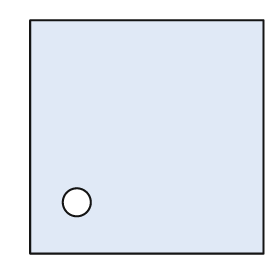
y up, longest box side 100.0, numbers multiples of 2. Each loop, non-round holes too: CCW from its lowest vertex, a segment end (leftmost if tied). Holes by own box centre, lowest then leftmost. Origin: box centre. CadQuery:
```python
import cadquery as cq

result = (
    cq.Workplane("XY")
    .moveTo(-50.0, -50.0)
    .lineTo(50.0, -50.0)
    .lineTo(50.0, 50.0)
    .lineTo(-50.0, 50.0)
    .close()
    .moveTo(-30.0, -28.0)
    .circle(6.0)
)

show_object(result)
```